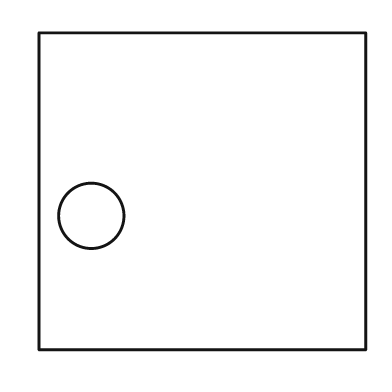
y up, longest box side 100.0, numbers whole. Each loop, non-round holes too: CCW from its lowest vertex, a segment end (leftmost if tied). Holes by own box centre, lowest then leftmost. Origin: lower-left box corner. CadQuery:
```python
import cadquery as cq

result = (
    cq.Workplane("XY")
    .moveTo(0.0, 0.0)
    .lineTo(100.0, 0.0)
    .lineTo(100.0, 97.0)
    .lineTo(0.0, 97.0)
    .close()
    .moveTo(16.0, 41.0)
    .circle(10.0)
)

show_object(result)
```